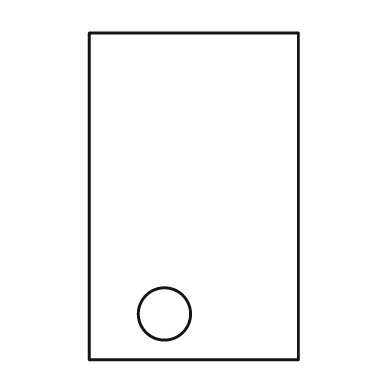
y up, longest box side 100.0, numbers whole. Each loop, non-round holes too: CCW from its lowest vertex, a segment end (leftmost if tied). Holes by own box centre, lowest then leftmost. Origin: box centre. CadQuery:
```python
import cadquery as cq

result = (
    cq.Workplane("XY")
    .moveTo(-32.0, -50.0)
    .lineTo(32.0, -50.0)
    .lineTo(32.0, 50.0)
    .lineTo(-32.0, 50.0)
    .close()
    .moveTo(-9.0, -36.0)
    .circle(8.0)
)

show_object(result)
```